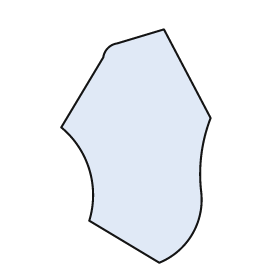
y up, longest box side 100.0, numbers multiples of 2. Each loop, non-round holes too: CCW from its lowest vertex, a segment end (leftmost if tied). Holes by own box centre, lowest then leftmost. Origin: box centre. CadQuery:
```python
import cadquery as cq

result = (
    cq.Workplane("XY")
    .moveTo(10.0, -50.0)
    .threePointArc((24.0, -38.0), (28.0, -20.0))
    .threePointArc((28.0, -4.0), (32.0, 12.0))
    .lineTo(12.0, 50.0)
    .lineTo(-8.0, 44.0)
    .threePointArc((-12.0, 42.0), (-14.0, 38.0))
    .lineTo(-32.0, 8.0)
    .threePointArc((-20.0, -10.0), (-20.0, -32.0))
    .close()
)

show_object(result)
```